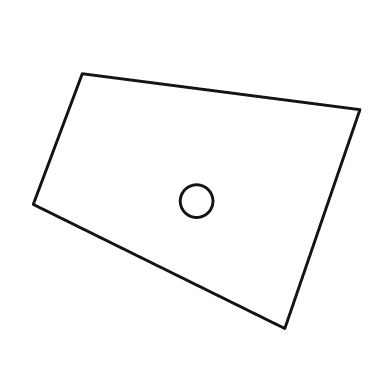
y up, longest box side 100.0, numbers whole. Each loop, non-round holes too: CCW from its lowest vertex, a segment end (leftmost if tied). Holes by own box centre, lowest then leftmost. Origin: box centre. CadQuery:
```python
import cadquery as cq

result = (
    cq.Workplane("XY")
    .moveTo(27.0, -39.0)
    .lineTo(50.0, 28.0)
    .lineTo(-35.0, 39.0)
    .lineTo(-50.0, -1.0)
    .close()
    .moveTo(0.0, 0.0)
    .circle(5.0)
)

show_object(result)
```